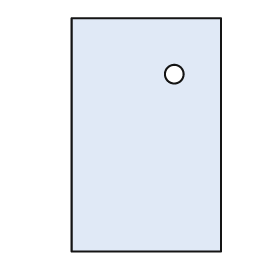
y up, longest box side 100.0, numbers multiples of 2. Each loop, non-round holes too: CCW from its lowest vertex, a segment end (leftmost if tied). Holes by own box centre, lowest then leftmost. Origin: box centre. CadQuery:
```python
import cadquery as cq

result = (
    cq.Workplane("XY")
    .moveTo(-32.0, -50.0)
    .lineTo(32.0, -50.0)
    .lineTo(32.0, 50.0)
    .lineTo(-32.0, 50.0)
    .close()
    .moveTo(12.0, 26.0)
    .circle(4.0)
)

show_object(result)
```